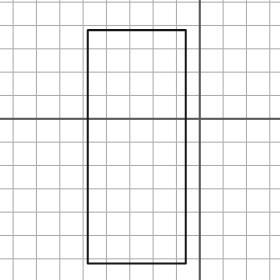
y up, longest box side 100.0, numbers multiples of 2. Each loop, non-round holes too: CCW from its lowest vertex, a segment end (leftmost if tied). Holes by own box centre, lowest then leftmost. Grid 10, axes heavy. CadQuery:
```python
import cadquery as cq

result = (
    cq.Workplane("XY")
    .moveTo(-48.0, -62.0)
    .lineTo(-6.0, -62.0)
    .lineTo(-6.0, 38.0)
    .lineTo(-48.0, 38.0)
    .close()
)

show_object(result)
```